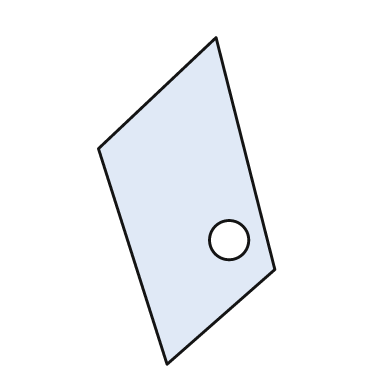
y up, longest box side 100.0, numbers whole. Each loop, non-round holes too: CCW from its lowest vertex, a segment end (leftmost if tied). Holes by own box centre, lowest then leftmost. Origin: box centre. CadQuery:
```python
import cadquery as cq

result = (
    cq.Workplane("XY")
    .moveTo(-6.0, -50.0)
    .lineTo(27.0, -21.0)
    .lineTo(9.0, 50.0)
    .lineTo(-27.0, 16.0)
    .close()
    .moveTo(13.0, -12.0)
    .circle(6.0)
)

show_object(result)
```